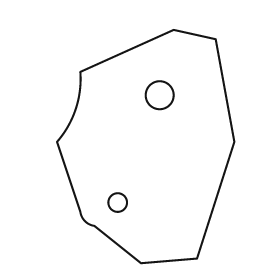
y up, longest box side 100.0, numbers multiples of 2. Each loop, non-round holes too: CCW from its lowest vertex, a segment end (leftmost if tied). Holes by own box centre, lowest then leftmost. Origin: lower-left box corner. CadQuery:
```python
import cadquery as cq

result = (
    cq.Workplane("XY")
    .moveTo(36.0, 0.0)
    .lineTo(60.0, 2.0)
    .lineTo(76.0, 52.0)
    .lineTo(68.0, 96.0)
    .lineTo(50.0, 100.0)
    .lineTo(10.0, 82.0)
    .threePointArc((8.0, 66.0), (0.0, 52.0))
    .lineTo(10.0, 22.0)
    .threePointArc((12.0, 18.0), (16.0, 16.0))
    .close()
    .moveTo(26.0, 26.0)
    .circle(4.0)
    .moveTo(44.0, 72.0)
    .circle(6.0)
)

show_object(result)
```